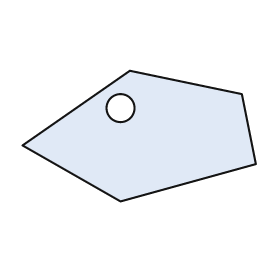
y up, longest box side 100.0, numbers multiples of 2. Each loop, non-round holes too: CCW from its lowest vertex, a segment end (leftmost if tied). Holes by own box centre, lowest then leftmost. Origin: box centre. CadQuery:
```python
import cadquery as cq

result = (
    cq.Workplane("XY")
    .moveTo(-8.0, -28.0)
    .lineTo(50.0, -12.0)
    .lineTo(44.0, 18.0)
    .lineTo(-4.0, 28.0)
    .lineTo(-50.0, -4.0)
    .close()
    .moveTo(-8.0, 12.0)
    .circle(6.0)
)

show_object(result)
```